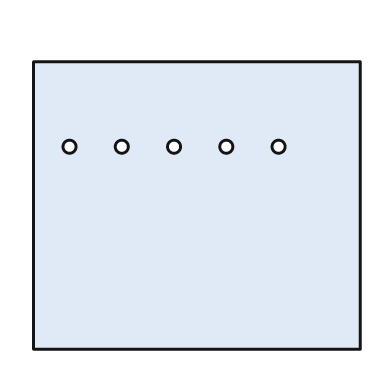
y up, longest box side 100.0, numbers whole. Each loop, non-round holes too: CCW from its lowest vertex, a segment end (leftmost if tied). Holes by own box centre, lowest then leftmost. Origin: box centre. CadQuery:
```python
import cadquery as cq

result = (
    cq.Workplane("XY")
    .moveTo(-50.0, -44.0)
    .lineTo(50.0, -44.0)
    .lineTo(50.0, 44.0)
    .lineTo(-50.0, 44.0)
    .close()
    .moveTo(-39.0, 18.0)
    .circle(2.0)
    .moveTo(-23.0, 18.0)
    .circle(2.0)
    .moveTo(-7.0, 18.0)
    .circle(2.0)
    .moveTo(9.0, 18.0)
    .circle(2.0)
    .moveTo(25.0, 18.0)
    .circle(2.0)
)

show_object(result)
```